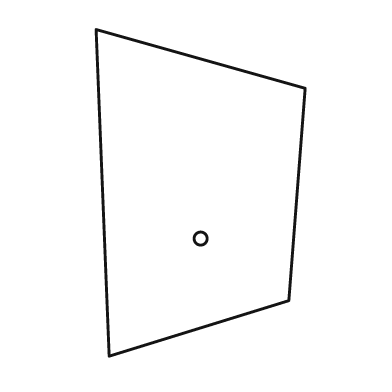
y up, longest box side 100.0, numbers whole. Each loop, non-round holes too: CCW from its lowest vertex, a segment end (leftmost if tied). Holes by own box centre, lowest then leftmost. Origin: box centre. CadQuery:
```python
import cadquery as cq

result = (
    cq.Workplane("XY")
    .moveTo(-28.0, -50.0)
    .lineTo(27.0, -33.0)
    .lineTo(32.0, 32.0)
    .lineTo(-32.0, 50.0)
    .close()
    .moveTo(0.0, -14.0)
    .circle(2.0)
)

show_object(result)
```